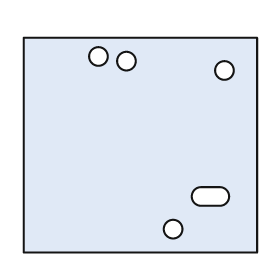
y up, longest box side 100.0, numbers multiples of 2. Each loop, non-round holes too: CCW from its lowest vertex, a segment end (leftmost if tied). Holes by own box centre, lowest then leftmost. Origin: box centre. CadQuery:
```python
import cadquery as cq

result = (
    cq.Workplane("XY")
    .moveTo(-50.0, -46.0)
    .lineTo(50.0, -46.0)
    .lineTo(50.0, 46.0)
    .lineTo(-50.0, 46.0)
    .close()
    .moveTo(14.0, -36.0)
    .circle(4.0)
    .moveTo(26.0, -26.0)
    .lineTo(34.0, -26.0)
    .threePointArc((38.0, -22.0), (34.0, -18.0))
    .lineTo(26.0, -18.0)
    .threePointArc((22.0, -22.0), (26.0, -26.0))
    .close()
    .moveTo(36.0, 32.0)
    .circle(4.0)
    .moveTo(-6.0, 36.0)
    .circle(4.0)
    .moveTo(-18.0, 38.0)
    .circle(4.0)
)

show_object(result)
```